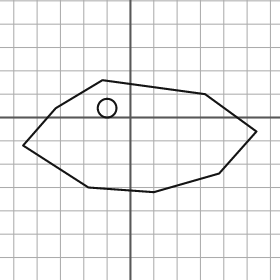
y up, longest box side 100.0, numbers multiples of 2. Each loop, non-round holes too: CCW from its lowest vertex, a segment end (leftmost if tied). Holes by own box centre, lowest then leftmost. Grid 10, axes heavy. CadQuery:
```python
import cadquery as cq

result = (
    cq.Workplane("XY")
    .moveTo(10.0, -32.0)
    .lineTo(38.0, -24.0)
    .lineTo(54.0, -6.0)
    .lineTo(32.0, 10.0)
    .lineTo(-12.0, 16.0)
    .lineTo(-32.0, 4.0)
    .lineTo(-46.0, -12.0)
    .lineTo(-18.0, -30.0)
    .close()
    .moveTo(-10.0, 4.0)
    .circle(4.0)
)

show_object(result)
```